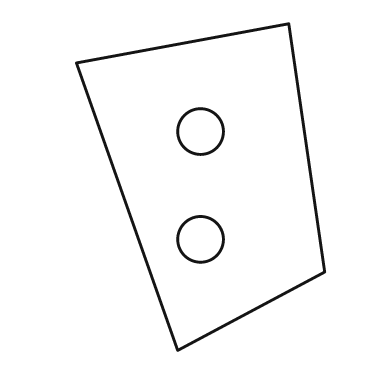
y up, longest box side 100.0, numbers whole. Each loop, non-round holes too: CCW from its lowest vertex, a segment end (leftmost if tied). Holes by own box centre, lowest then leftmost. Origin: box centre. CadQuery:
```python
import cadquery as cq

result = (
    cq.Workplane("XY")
    .moveTo(-7.0, -50.0)
    .lineTo(38.0, -26.0)
    .lineTo(27.0, 50.0)
    .lineTo(-38.0, 38.0)
    .close()
    .moveTo(0.0, -16.0)
    .circle(7.0)
    .moveTo(0.0, 17.0)
    .circle(7.0)
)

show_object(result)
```